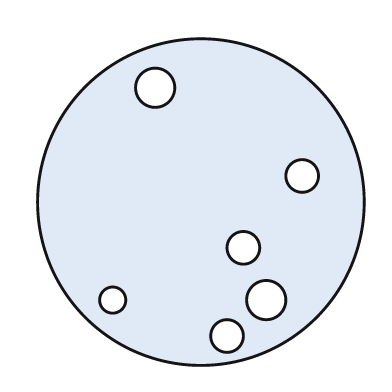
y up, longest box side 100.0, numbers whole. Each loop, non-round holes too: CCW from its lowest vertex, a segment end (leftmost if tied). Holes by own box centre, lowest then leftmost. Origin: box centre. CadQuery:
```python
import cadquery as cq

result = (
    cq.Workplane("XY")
    .moveTo(0.0, 0.0)
    .circle(50.0)
    .moveTo(8.0, -41.0)
    .circle(5.0)
    .moveTo(-27.0, -30.0)
    .circle(4.0)
    .moveTo(20.0, -30.0)
    .circle(6.0)
    .moveTo(13.0, -14.0)
    .circle(5.0)
    .moveTo(31.0, 8.0)
    .circle(5.0)
    .moveTo(-14.0, 35.0)
    .circle(6.0)
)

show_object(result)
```